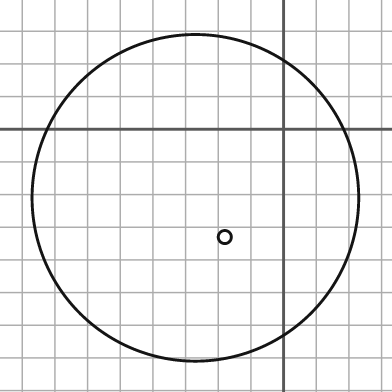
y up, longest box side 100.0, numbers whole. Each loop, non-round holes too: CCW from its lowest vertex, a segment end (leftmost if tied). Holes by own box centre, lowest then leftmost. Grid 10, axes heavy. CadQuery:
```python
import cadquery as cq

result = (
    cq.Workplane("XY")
    .moveTo(-27.0, -21.0)
    .circle(50.0)
    .moveTo(-18.0, -33.0)
    .circle(2.0)
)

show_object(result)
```